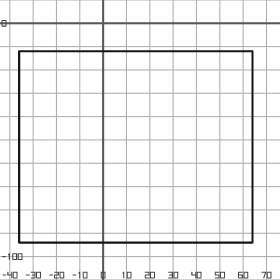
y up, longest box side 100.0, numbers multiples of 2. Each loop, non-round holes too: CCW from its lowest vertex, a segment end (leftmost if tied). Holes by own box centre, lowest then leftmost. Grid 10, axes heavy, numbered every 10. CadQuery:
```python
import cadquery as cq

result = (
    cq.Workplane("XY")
    .moveTo(-36.0, -94.0)
    .lineTo(64.0, -94.0)
    .lineTo(64.0, -12.0)
    .lineTo(-36.0, -12.0)
    .close()
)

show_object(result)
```